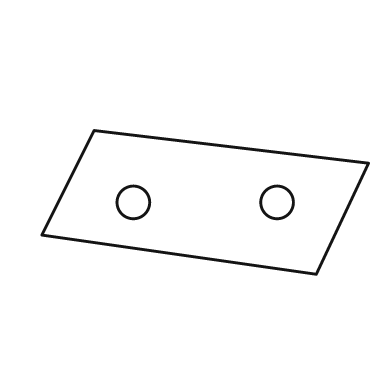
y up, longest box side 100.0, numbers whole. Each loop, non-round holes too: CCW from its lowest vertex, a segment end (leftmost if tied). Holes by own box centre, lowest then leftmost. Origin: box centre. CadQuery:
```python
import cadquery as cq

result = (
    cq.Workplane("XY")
    .moveTo(34.0, -22.0)
    .lineTo(50.0, 12.0)
    .lineTo(-34.0, 22.0)
    .lineTo(-50.0, -10.0)
    .close()
    .moveTo(-22.0, 0.0)
    .circle(5.0)
    .moveTo(22.0, 0.0)
    .circle(5.0)
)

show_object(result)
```